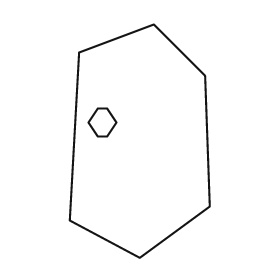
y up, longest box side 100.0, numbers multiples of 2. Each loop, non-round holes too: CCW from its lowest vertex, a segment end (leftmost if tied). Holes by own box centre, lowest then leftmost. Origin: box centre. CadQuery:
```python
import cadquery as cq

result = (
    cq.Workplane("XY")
    .moveTo(0.0, -50.0)
    .lineTo(30.0, -28.0)
    .lineTo(28.0, 28.0)
    .lineTo(6.0, 50.0)
    .lineTo(-26.0, 38.0)
    .lineTo(-30.0, -34.0)
    .close()
    .moveTo(-18.0, 2.0)
    .lineTo(-14.0, 2.0)
    .lineTo(-10.0, 8.0)
    .lineTo(-14.0, 14.0)
    .lineTo(-18.0, 14.0)
    .lineTo(-22.0, 8.0)
    .close()
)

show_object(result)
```